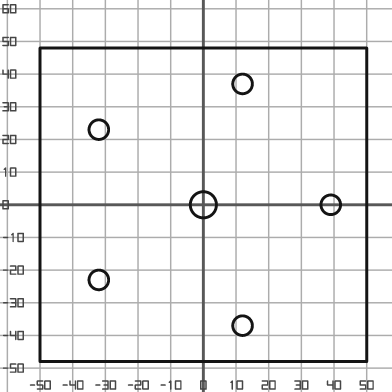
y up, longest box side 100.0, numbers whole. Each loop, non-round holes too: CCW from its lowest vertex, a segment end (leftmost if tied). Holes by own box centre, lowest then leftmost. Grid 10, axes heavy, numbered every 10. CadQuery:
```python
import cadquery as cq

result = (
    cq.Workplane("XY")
    .moveTo(-50.0, -48.0)
    .lineTo(50.0, -48.0)
    .lineTo(50.0, 48.0)
    .lineTo(-50.0, 48.0)
    .close()
    .moveTo(12.0, -37.0)
    .circle(3.0)
    .moveTo(-32.0, -23.0)
    .circle(3.0)
    .moveTo(0.0, 0.0)
    .circle(4.0)
    .moveTo(39.0, 0.0)
    .circle(3.0)
    .moveTo(-32.0, 23.0)
    .circle(3.0)
    .moveTo(12.0, 37.0)
    .circle(3.0)
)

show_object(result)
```